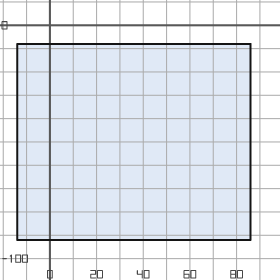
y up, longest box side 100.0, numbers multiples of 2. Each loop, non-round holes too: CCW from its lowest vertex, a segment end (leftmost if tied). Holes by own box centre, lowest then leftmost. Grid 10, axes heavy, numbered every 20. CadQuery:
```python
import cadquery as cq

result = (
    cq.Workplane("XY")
    .moveTo(-14.0, -92.0)
    .lineTo(86.0, -92.0)
    .lineTo(86.0, -8.0)
    .lineTo(-14.0, -8.0)
    .close()
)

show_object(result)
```